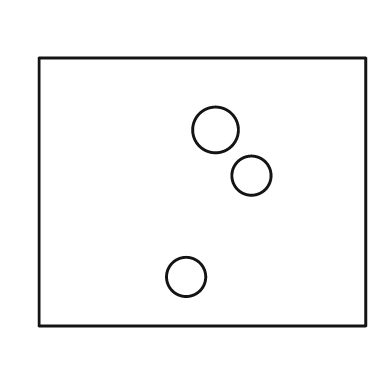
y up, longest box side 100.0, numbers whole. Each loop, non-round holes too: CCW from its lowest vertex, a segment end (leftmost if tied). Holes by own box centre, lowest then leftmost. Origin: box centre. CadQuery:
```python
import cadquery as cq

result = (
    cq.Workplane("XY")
    .moveTo(-50.0, -41.0)
    .lineTo(50.0, -41.0)
    .lineTo(50.0, 41.0)
    .lineTo(-50.0, 41.0)
    .close()
    .moveTo(-5.0, -26.0)
    .circle(6.0)
    .moveTo(15.0, 5.0)
    .circle(6.0)
    .moveTo(4.0, 19.0)
    .circle(7.0)
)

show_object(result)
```